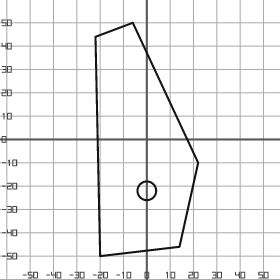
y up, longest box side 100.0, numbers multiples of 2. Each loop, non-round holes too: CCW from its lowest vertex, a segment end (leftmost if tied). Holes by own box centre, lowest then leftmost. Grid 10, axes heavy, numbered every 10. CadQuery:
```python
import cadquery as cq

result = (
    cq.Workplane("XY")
    .moveTo(-20.0, -50.0)
    .lineTo(14.0, -46.0)
    .lineTo(22.0, -10.0)
    .lineTo(-6.0, 50.0)
    .lineTo(-22.0, 44.0)
    .close()
    .moveTo(0.0, -22.0)
    .circle(4.0)
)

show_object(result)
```